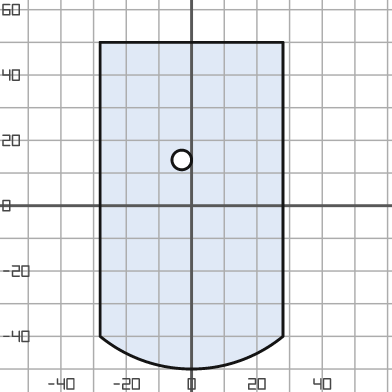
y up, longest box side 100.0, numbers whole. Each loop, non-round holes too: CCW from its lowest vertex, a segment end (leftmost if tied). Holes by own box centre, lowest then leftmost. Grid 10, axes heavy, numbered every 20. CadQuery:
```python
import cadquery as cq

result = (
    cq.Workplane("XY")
    .moveTo(-28.0, -40.0)
    .threePointArc((0.0, -50.0), (28.0, -40.0))
    .lineTo(28.0, 50.0)
    .lineTo(-28.0, 50.0)
    .close()
    .moveTo(-3.0, 14.0)
    .circle(3.0)
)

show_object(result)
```